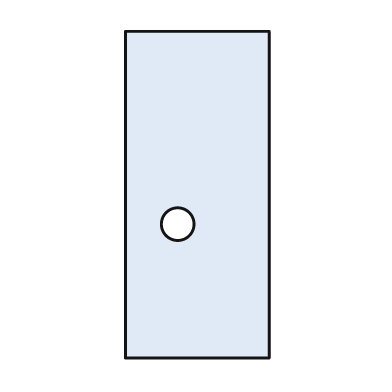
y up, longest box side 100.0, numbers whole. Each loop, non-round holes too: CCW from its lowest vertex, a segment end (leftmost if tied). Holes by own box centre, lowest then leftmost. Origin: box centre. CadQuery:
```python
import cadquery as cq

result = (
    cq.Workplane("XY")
    .moveTo(-22.0, -50.0)
    .lineTo(22.0, -50.0)
    .lineTo(22.0, 50.0)
    .lineTo(-22.0, 50.0)
    .close()
    .moveTo(-6.0, -9.0)
    .circle(5.0)
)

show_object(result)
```